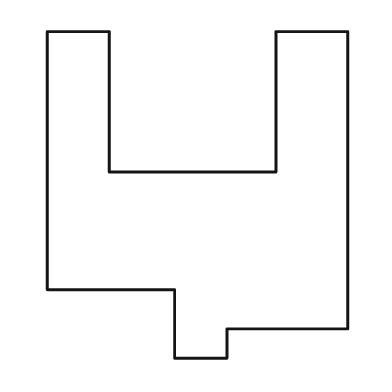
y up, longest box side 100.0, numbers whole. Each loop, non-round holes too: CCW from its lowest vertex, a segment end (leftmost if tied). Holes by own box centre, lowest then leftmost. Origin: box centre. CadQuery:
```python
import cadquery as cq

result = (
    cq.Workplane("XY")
    .moveTo(-7.0, -50.0)
    .lineTo(9.0, -50.0)
    .lineTo(9.0, -41.0)
    .lineTo(46.0, -41.0)
    .lineTo(46.0, 50.0)
    .lineTo(24.0, 50.0)
    .lineTo(24.0, 7.0)
    .lineTo(-27.0, 7.0)
    .lineTo(-27.0, 50.0)
    .lineTo(-46.0, 50.0)
    .lineTo(-46.0, -29.0)
    .lineTo(-7.0, -29.0)
    .close()
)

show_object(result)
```